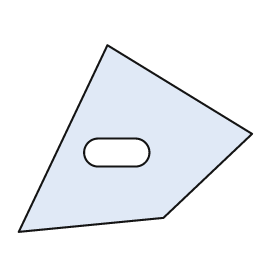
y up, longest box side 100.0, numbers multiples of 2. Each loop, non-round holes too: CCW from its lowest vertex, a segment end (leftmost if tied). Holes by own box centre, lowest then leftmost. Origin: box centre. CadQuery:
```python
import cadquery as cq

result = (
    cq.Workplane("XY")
    .moveTo(-50.0, -40.0)
    .lineTo(12.0, -34.0)
    .lineTo(50.0, 2.0)
    .lineTo(-12.0, 40.0)
    .close()
    .moveTo(-16.0, -12.0)
    .lineTo(0.0, -12.0)
    .threePointArc((6.0, -6.0), (0.0, 0.0))
    .lineTo(-16.0, 0.0)
    .threePointArc((-22.0, -6.0), (-16.0, -12.0))
    .close()
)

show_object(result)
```